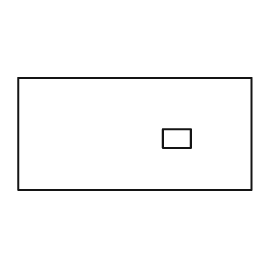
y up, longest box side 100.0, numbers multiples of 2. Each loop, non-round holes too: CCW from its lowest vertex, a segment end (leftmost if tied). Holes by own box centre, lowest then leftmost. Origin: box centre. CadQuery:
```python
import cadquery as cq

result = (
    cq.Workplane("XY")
    .moveTo(-50.0, -24.0)
    .lineTo(50.0, -24.0)
    .lineTo(50.0, 24.0)
    .lineTo(-50.0, 24.0)
    .close()
    .moveTo(12.0, -6.0)
    .lineTo(24.0, -6.0)
    .lineTo(24.0, 2.0)
    .lineTo(12.0, 2.0)
    .close()
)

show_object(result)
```